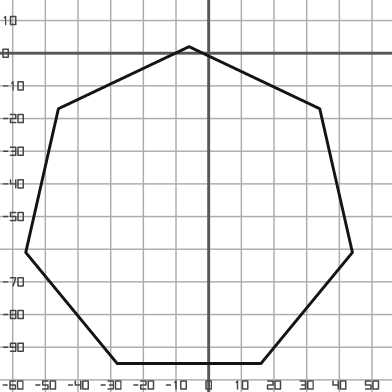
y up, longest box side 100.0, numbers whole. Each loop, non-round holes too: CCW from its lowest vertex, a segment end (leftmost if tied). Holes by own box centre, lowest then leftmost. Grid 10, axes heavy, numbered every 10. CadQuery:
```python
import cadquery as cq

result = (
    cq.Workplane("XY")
    .moveTo(-28.0, -95.0)
    .lineTo(16.0, -95.0)
    .lineTo(44.0, -61.0)
    .lineTo(34.0, -17.0)
    .lineTo(-6.0, 2.0)
    .lineTo(-46.0, -17.0)
    .lineTo(-56.0, -61.0)
    .close()
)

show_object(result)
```